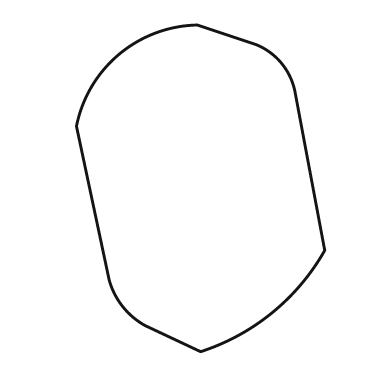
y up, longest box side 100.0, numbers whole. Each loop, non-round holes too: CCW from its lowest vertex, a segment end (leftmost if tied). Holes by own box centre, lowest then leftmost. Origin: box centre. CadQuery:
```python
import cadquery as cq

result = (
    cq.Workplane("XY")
    .moveTo(0.0, -50.0)
    .threePointArc((22.0, -38.0), (38.0, -19.0))
    .lineTo(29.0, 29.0)
    .threePointArc((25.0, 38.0), (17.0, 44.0))
    .lineTo(-1.0, 50.0)
    .threePointArc((-25.0, 41.0), (-38.0, 19.0))
    .lineTo(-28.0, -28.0)
    .threePointArc((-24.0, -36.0), (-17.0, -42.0))
    .close()
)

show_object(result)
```